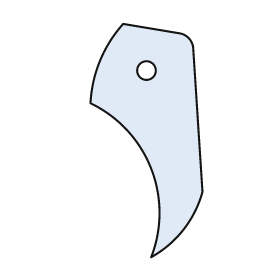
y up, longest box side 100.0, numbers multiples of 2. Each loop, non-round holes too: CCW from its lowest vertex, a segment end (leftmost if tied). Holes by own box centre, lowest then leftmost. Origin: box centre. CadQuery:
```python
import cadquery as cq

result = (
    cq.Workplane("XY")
    .moveTo(2.0, -50.0)
    .threePointArc((16.0, -38.0), (24.0, -22.0))
    .lineTo(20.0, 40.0)
    .threePointArc((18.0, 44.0), (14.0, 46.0))
    .lineTo(-10.0, 50.0)
    .threePointArc((-20.0, 34.0), (-24.0, 16.0))
    .threePointArc((2.0, -12.0), (2.0, -50.0))
    .close()
    .moveTo(0.0, 30.0)
    .circle(4.0)
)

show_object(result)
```